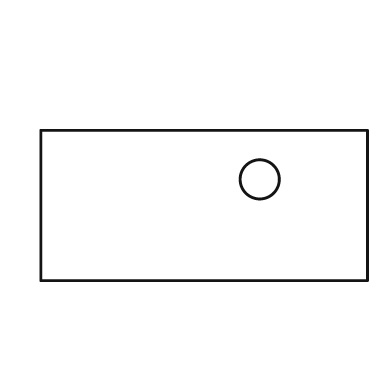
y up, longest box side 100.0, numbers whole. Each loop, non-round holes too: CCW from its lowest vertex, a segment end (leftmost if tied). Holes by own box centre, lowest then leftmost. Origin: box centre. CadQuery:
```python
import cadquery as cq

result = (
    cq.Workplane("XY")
    .moveTo(-50.0, -23.0)
    .lineTo(50.0, -23.0)
    .lineTo(50.0, 23.0)
    .lineTo(-50.0, 23.0)
    .close()
    .moveTo(17.0, 8.0)
    .circle(6.0)
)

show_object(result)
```